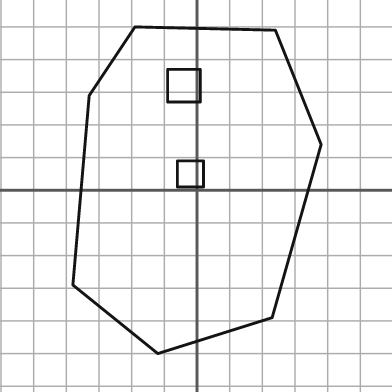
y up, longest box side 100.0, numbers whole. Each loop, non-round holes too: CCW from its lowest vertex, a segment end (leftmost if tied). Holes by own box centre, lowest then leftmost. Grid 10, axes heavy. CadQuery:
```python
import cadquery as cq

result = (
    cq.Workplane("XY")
    .moveTo(-12.0, -50.0)
    .lineTo(23.0, -39.0)
    .lineTo(38.0, 14.0)
    .lineTo(24.0, 49.0)
    .lineTo(-19.0, 50.0)
    .lineTo(-33.0, 29.0)
    .lineTo(-38.0, -29.0)
    .close()
    .moveTo(-6.0, 1.0)
    .lineTo(2.0, 1.0)
    .lineTo(2.0, 9.0)
    .lineTo(-6.0, 9.0)
    .close()
    .moveTo(-9.0, 27.0)
    .lineTo(1.0, 27.0)
    .lineTo(1.0, 37.0)
    .lineTo(-9.0, 37.0)
    .close()
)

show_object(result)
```